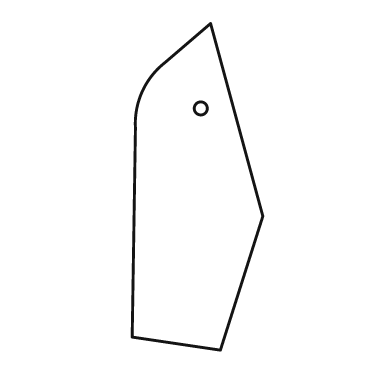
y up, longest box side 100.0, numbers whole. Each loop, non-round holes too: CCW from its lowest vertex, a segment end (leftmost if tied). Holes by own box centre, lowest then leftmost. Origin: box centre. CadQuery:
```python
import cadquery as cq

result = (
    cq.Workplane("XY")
    .moveTo(7.0, -50.0)
    .lineTo(20.0, -9.0)
    .lineTo(4.0, 50.0)
    .lineTo(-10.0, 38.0)
    .threePointArc((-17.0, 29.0), (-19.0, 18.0))
    .lineTo(-20.0, -46.0)
    .close()
    .moveTo(1.0, 24.0)
    .circle(2.0)
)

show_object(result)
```